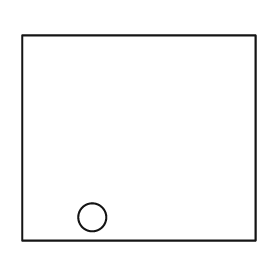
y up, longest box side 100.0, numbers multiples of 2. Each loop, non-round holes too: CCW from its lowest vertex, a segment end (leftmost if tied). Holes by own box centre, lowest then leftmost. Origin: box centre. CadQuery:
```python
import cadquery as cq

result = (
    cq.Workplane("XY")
    .moveTo(-50.0, -44.0)
    .lineTo(50.0, -44.0)
    .lineTo(50.0, 44.0)
    .lineTo(-50.0, 44.0)
    .close()
    .moveTo(-20.0, -34.0)
    .circle(6.0)
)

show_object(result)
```